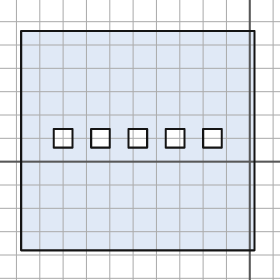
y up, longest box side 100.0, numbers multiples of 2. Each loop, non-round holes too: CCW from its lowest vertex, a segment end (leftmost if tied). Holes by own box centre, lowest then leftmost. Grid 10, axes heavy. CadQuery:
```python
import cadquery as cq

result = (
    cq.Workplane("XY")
    .moveTo(-98.0, -38.0)
    .lineTo(2.0, -38.0)
    .lineTo(2.0, 56.0)
    .lineTo(-98.0, 56.0)
    .close()
    .moveTo(-84.0, 6.0)
    .lineTo(-76.0, 6.0)
    .lineTo(-76.0, 14.0)
    .lineTo(-84.0, 14.0)
    .close()
    .moveTo(-68.0, 6.0)
    .lineTo(-60.0, 6.0)
    .lineTo(-60.0, 14.0)
    .lineTo(-68.0, 14.0)
    .close()
    .moveTo(-52.0, 6.0)
    .lineTo(-44.0, 6.0)
    .lineTo(-44.0, 14.0)
    .lineTo(-52.0, 14.0)
    .close()
    .moveTo(-36.0, 6.0)
    .lineTo(-28.0, 6.0)
    .lineTo(-28.0, 14.0)
    .lineTo(-36.0, 14.0)
    .close()
    .moveTo(-20.0, 6.0)
    .lineTo(-12.0, 6.0)
    .lineTo(-12.0, 14.0)
    .lineTo(-20.0, 14.0)
    .close()
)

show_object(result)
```